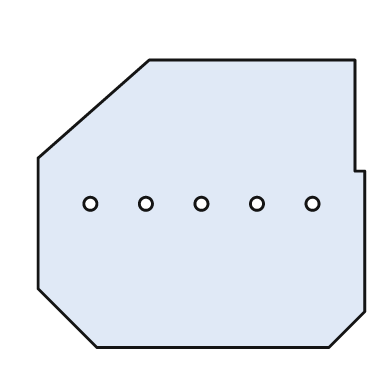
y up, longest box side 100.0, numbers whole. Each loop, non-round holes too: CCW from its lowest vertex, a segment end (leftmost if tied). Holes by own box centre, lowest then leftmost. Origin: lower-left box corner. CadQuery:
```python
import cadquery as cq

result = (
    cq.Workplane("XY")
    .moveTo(18.0, 0.0)
    .lineTo(89.0, 0.0)
    .lineTo(100.0, 11.0)
    .lineTo(100.0, 54.0)
    .lineTo(97.0, 54.0)
    .lineTo(97.0, 88.0)
    .lineTo(34.0, 88.0)
    .lineTo(0.0, 58.0)
    .lineTo(0.0, 18.0)
    .close()
    .moveTo(16.0, 44.0)
    .circle(2.0)
    .moveTo(33.0, 44.0)
    .circle(2.0)
    .moveTo(50.0, 44.0)
    .circle(2.0)
    .moveTo(67.0, 44.0)
    .circle(2.0)
    .moveTo(84.0, 44.0)
    .circle(2.0)
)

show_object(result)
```